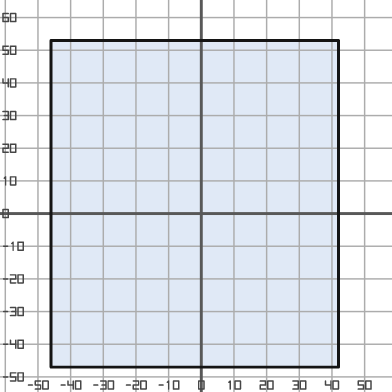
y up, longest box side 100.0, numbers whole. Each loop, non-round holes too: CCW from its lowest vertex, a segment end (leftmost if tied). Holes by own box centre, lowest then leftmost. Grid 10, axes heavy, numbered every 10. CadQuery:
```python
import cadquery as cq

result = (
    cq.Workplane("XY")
    .moveTo(-46.0, -47.0)
    .lineTo(42.0, -47.0)
    .lineTo(42.0, 53.0)
    .lineTo(-46.0, 53.0)
    .close()
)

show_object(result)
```